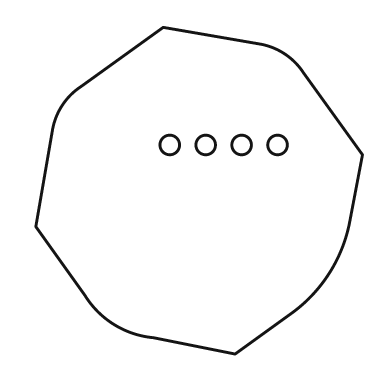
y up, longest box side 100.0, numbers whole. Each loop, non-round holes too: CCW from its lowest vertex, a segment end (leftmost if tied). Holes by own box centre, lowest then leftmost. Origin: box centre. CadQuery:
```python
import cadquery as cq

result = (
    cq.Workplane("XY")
    .moveTo(11.0, -50.0)
    .lineTo(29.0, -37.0)
    .threePointArc((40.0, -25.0), (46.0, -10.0))
    .lineTo(50.0, 11.0)
    .lineTo(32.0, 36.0)
    .threePointArc((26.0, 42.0), (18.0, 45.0))
    .lineTo(-11.0, 50.0)
    .lineTo(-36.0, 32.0)
    .threePointArc((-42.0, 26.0), (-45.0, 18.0))
    .lineTo(-50.0, -11.0)
    .lineTo(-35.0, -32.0)
    .threePointArc((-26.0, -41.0), (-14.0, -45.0))
    .close()
    .moveTo(-9.0, 14.0)
    .circle(3.0)
    .moveTo(2.0, 14.0)
    .circle(3.0)
    .moveTo(13.0, 14.0)
    .circle(3.0)
    .moveTo(24.0, 14.0)
    .circle(3.0)
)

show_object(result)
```